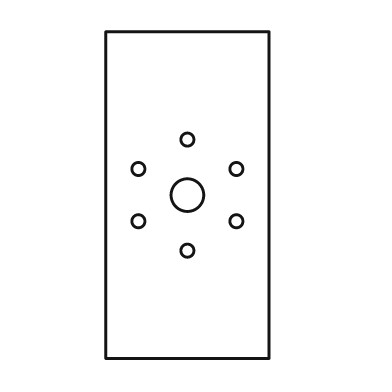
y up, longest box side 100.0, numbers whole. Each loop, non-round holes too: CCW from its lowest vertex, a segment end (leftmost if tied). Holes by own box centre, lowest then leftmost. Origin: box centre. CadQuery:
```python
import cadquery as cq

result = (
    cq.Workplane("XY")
    .moveTo(-25.0, -50.0)
    .lineTo(25.0, -50.0)
    .lineTo(25.0, 50.0)
    .lineTo(-25.0, 50.0)
    .close()
    .moveTo(0.0, -17.0)
    .circle(2.0)
    .moveTo(-15.0, -8.0)
    .circle(2.0)
    .moveTo(15.0, -8.0)
    .circle(2.0)
    .moveTo(0.0, 0.0)
    .circle(5.0)
    .moveTo(-15.0, 8.0)
    .circle(2.0)
    .moveTo(15.0, 8.0)
    .circle(2.0)
    .moveTo(0.0, 17.0)
    .circle(2.0)
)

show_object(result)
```